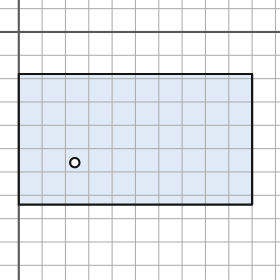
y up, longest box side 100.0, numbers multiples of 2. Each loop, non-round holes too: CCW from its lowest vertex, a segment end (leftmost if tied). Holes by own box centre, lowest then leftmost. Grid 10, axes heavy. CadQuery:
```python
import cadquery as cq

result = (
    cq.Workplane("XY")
    .moveTo(0.0, -74.0)
    .lineTo(100.0, -74.0)
    .lineTo(100.0, -18.0)
    .lineTo(0.0, -18.0)
    .close()
    .moveTo(24.0, -56.0)
    .circle(2.0)
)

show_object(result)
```